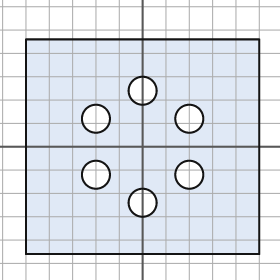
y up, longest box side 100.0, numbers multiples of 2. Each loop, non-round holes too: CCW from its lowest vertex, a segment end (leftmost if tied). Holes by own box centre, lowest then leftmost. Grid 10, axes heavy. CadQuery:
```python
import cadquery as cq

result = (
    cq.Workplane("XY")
    .moveTo(-50.0, -46.0)
    .lineTo(50.0, -46.0)
    .lineTo(50.0, 46.0)
    .lineTo(-50.0, 46.0)
    .close()
    .moveTo(0.0, -24.0)
    .circle(6.0)
    .moveTo(-20.0, -12.0)
    .circle(6.0)
    .moveTo(20.0, -12.0)
    .circle(6.0)
    .moveTo(-20.0, 12.0)
    .circle(6.0)
    .moveTo(20.0, 12.0)
    .circle(6.0)
    .moveTo(0.0, 24.0)
    .circle(6.0)
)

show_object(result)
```